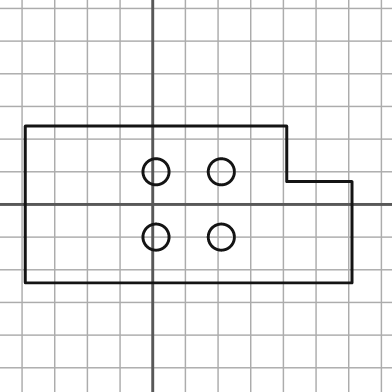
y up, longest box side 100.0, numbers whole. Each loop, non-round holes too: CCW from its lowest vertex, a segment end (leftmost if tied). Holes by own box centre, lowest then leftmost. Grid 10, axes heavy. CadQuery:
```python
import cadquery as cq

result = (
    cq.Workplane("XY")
    .moveTo(-39.0, -24.0)
    .lineTo(61.0, -24.0)
    .lineTo(61.0, 7.0)
    .lineTo(41.0, 7.0)
    .lineTo(41.0, 24.0)
    .lineTo(-39.0, 24.0)
    .close()
    .moveTo(1.0, -10.0)
    .circle(4.0)
    .moveTo(21.0, -10.0)
    .circle(4.0)
    .moveTo(1.0, 10.0)
    .circle(4.0)
    .moveTo(21.0, 10.0)
    .circle(4.0)
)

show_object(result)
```